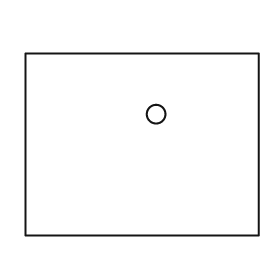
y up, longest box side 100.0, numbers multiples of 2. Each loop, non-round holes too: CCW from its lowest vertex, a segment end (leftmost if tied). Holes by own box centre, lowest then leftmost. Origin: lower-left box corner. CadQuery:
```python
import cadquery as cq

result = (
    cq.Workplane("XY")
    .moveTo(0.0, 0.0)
    .lineTo(100.0, 0.0)
    .lineTo(100.0, 78.0)
    .lineTo(0.0, 78.0)
    .close()
    .moveTo(56.0, 52.0)
    .circle(4.0)
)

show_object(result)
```